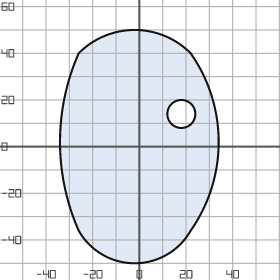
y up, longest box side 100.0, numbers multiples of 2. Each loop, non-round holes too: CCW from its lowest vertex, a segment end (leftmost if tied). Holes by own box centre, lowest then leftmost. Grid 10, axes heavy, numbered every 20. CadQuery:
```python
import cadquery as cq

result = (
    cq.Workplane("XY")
    .moveTo(-26.0, -36.0)
    .threePointArc((-2.0, -50.0), (22.0, -36.0))
    .threePointArc((34.0, 2.0), (22.0, 40.0))
    .threePointArc((-2.0, 50.0), (-26.0, 40.0))
    .threePointArc((-34.0, 2.0), (-26.0, -36.0))
    .close()
    .moveTo(18.0, 14.0)
    .circle(6.0)
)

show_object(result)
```